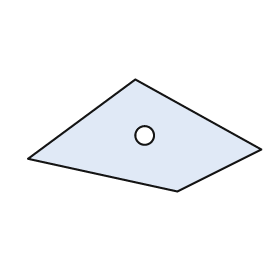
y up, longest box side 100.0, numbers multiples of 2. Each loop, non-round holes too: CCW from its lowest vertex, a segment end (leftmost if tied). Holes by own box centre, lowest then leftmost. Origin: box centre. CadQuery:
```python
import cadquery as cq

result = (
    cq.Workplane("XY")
    .moveTo(14.0, -24.0)
    .lineTo(50.0, -6.0)
    .lineTo(-4.0, 24.0)
    .lineTo(-50.0, -10.0)
    .close()
    .moveTo(0.0, 0.0)
    .circle(4.0)
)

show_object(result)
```